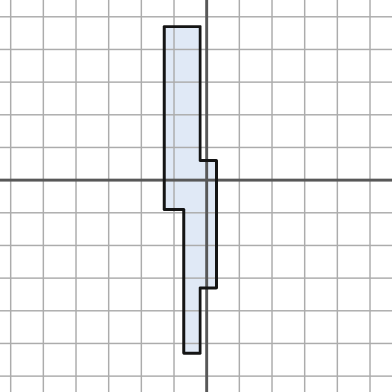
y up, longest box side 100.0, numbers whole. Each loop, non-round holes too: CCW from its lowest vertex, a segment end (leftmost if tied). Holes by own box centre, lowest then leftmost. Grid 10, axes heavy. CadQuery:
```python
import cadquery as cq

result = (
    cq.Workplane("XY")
    .moveTo(-7.0, -53.0)
    .lineTo(-2.0, -53.0)
    .lineTo(-2.0, -33.0)
    .lineTo(3.0, -33.0)
    .lineTo(3.0, 6.0)
    .lineTo(-2.0, 6.0)
    .lineTo(-2.0, 47.0)
    .lineTo(-13.0, 47.0)
    .lineTo(-13.0, -9.0)
    .lineTo(-7.0, -9.0)
    .close()
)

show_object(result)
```